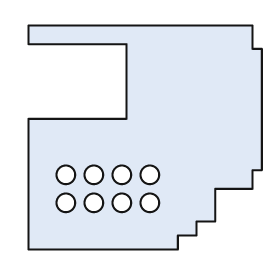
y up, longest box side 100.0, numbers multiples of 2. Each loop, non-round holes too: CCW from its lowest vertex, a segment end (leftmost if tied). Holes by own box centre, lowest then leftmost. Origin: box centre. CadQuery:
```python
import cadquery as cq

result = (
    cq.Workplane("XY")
    .moveTo(-50.0, -48.0)
    .lineTo(14.0, -48.0)
    .lineTo(14.0, -42.0)
    .lineTo(22.0, -42.0)
    .lineTo(22.0, -36.0)
    .lineTo(30.0, -36.0)
    .lineTo(30.0, -22.0)
    .lineTo(46.0, -22.0)
    .lineTo(46.0, -14.0)
    .lineTo(50.0, -14.0)
    .lineTo(50.0, 38.0)
    .lineTo(46.0, 38.0)
    .lineTo(46.0, 48.0)
    .lineTo(-50.0, 48.0)
    .lineTo(-50.0, 40.0)
    .lineTo(-8.0, 40.0)
    .lineTo(-8.0, 8.0)
    .lineTo(-50.0, 8.0)
    .close()
    .moveTo(-34.0, -28.0)
    .circle(4.0)
    .moveTo(-22.0, -28.0)
    .circle(4.0)
    .moveTo(-10.0, -28.0)
    .circle(4.0)
    .moveTo(2.0, -28.0)
    .circle(4.0)
    .moveTo(-34.0, -16.0)
    .circle(4.0)
    .moveTo(-22.0, -16.0)
    .circle(4.0)
    .moveTo(-10.0, -16.0)
    .circle(4.0)
    .moveTo(2.0, -16.0)
    .circle(4.0)
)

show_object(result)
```